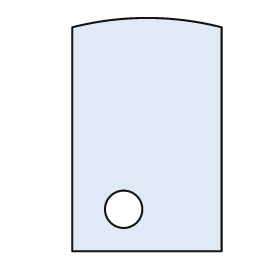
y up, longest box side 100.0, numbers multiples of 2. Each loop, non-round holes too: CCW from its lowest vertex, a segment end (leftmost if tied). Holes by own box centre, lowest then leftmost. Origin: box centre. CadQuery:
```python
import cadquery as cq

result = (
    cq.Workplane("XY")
    .moveTo(-32.0, -50.0)
    .lineTo(32.0, -50.0)
    .lineTo(32.0, 46.0)
    .threePointArc((0.0, 50.0), (-32.0, 46.0))
    .close()
    .moveTo(-10.0, -32.0)
    .circle(8.0)
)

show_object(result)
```